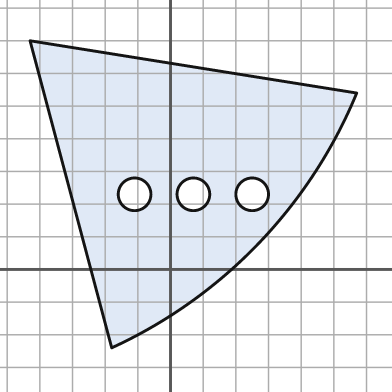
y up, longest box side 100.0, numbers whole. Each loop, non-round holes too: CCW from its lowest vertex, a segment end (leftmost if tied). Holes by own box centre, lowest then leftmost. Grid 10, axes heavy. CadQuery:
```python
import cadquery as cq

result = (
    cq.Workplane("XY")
    .moveTo(-18.0, -24.0)
    .threePointArc((27.0, 8.0), (57.0, 54.0))
    .lineTo(-43.0, 70.0)
    .close()
    .moveTo(-11.0, 23.0)
    .circle(5.0)
    .moveTo(7.0, 23.0)
    .circle(5.0)
    .moveTo(25.0, 23.0)
    .circle(5.0)
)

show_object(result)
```